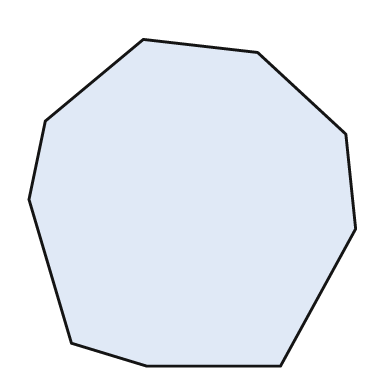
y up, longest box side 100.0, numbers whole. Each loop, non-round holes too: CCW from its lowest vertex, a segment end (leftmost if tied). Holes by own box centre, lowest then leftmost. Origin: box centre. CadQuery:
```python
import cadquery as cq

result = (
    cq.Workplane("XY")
    .moveTo(-14.0, -50.0)
    .lineTo(27.0, -50.0)
    .lineTo(50.0, -8.0)
    .lineTo(47.0, 21.0)
    .lineTo(20.0, 46.0)
    .lineTo(-15.0, 50.0)
    .lineTo(-45.0, 25.0)
    .lineTo(-50.0, 1.0)
    .lineTo(-37.0, -43.0)
    .close()
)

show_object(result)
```